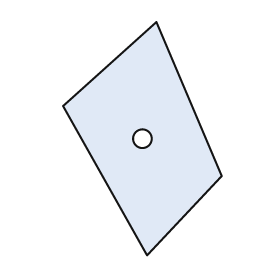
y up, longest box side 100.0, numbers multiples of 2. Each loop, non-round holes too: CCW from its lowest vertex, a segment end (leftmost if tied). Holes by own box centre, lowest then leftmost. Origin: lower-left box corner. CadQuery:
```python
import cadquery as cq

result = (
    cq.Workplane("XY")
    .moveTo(36.0, 0.0)
    .lineTo(68.0, 34.0)
    .lineTo(40.0, 100.0)
    .lineTo(0.0, 64.0)
    .close()
    .moveTo(34.0, 50.0)
    .circle(4.0)
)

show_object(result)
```